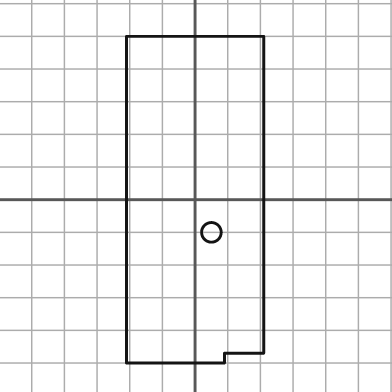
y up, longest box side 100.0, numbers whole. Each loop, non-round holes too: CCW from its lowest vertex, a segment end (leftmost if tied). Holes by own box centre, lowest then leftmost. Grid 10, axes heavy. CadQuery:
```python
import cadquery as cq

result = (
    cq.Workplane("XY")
    .moveTo(-21.0, -50.0)
    .lineTo(9.0, -50.0)
    .lineTo(9.0, -47.0)
    .lineTo(21.0, -47.0)
    .lineTo(21.0, 50.0)
    .lineTo(-21.0, 50.0)
    .close()
    .moveTo(5.0, -10.0)
    .circle(3.0)
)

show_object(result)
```